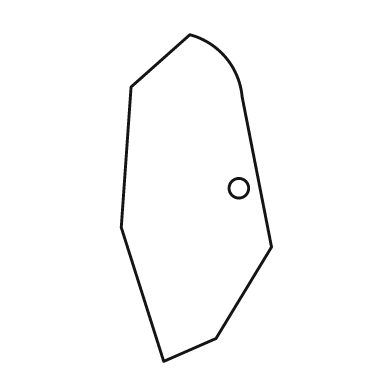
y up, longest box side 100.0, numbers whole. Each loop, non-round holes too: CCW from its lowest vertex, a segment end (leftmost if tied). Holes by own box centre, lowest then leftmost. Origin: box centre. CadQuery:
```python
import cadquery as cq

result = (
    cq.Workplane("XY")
    .moveTo(-10.0, -50.0)
    .lineTo(6.0, -43.0)
    .lineTo(23.0, -15.0)
    .lineTo(14.0, 31.0)
    .threePointArc((9.0, 43.0), (-2.0, 50.0))
    .lineTo(-20.0, 34.0)
    .lineTo(-23.0, -9.0)
    .close()
    .moveTo(13.0, 3.0)
    .circle(3.0)
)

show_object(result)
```